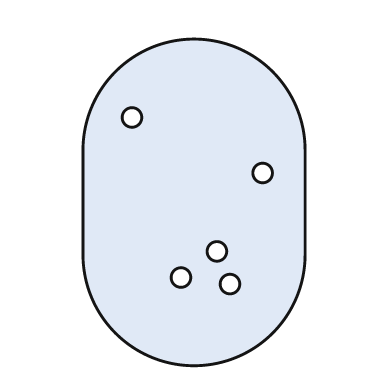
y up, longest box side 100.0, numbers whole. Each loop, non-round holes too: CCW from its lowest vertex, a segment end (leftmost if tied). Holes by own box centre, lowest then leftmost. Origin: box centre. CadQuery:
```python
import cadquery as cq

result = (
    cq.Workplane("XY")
    .moveTo(-34.0, -16.0)
    .threePointArc((0.0, -50.0), (34.0, -16.0))
    .lineTo(34.0, 16.0)
    .threePointArc((0.0, 50.0), (-34.0, 16.0))
    .close()
    .moveTo(11.0, -25.0)
    .circle(3.0)
    .moveTo(-4.0, -23.0)
    .circle(3.0)
    .moveTo(7.0, -15.0)
    .circle(3.0)
    .moveTo(21.0, 9.0)
    .circle(3.0)
    .moveTo(-19.0, 26.0)
    .circle(3.0)
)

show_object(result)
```